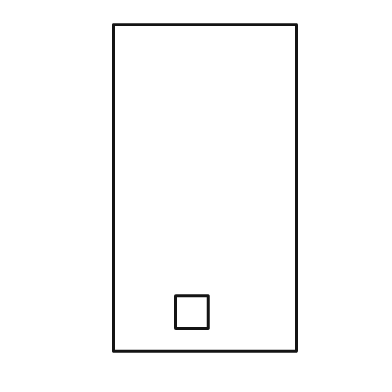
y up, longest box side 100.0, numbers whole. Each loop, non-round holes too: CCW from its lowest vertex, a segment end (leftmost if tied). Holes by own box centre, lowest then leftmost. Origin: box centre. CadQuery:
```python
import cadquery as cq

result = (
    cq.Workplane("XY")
    .moveTo(-28.0, -50.0)
    .lineTo(28.0, -50.0)
    .lineTo(28.0, 50.0)
    .lineTo(-28.0, 50.0)
    .close()
    .moveTo(-9.0, -43.0)
    .lineTo(1.0, -43.0)
    .lineTo(1.0, -33.0)
    .lineTo(-9.0, -33.0)
    .close()
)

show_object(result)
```